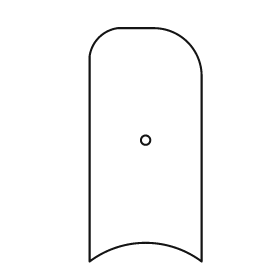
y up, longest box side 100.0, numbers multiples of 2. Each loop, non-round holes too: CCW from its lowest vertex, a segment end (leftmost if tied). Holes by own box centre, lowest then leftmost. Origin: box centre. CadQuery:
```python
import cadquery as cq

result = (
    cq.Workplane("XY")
    .moveTo(-24.0, -50.0)
    .threePointArc((0.0, -42.0), (24.0, -50.0))
    .lineTo(24.0, 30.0)
    .threePointArc((18.0, 44.0), (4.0, 50.0))
    .lineTo(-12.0, 50.0)
    .threePointArc((-20.0, 46.0), (-24.0, 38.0))
    .close()
    .moveTo(0.0, 2.0)
    .circle(2.0)
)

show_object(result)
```